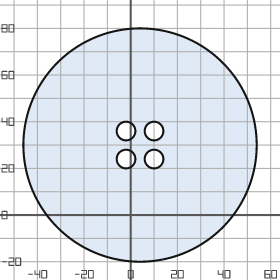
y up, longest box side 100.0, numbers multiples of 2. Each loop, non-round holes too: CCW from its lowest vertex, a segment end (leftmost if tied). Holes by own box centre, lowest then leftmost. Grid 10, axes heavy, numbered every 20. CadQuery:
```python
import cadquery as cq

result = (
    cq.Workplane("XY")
    .moveTo(4.0, 30.0)
    .circle(50.0)
    .moveTo(-2.0, 24.0)
    .circle(4.0)
    .moveTo(10.0, 24.0)
    .circle(4.0)
    .moveTo(-2.0, 36.0)
    .circle(4.0)
    .moveTo(10.0, 36.0)
    .circle(4.0)
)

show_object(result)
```